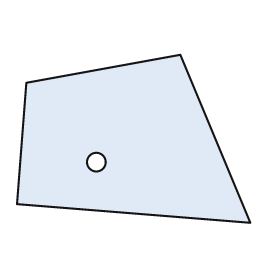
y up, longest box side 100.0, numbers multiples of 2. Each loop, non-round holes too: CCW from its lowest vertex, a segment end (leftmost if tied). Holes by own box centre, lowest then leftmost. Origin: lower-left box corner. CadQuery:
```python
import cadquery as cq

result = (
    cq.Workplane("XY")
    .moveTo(100.0, 0.0)
    .lineTo(70.0, 72.0)
    .lineTo(4.0, 60.0)
    .lineTo(0.0, 8.0)
    .close()
    .moveTo(34.0, 26.0)
    .circle(4.0)
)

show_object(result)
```